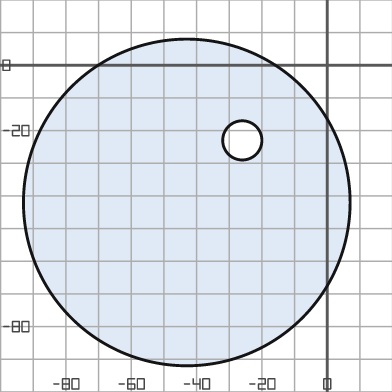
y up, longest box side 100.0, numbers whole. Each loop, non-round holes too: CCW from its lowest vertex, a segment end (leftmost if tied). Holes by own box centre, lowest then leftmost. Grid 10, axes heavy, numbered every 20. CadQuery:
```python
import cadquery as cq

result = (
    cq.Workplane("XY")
    .moveTo(-43.0, -42.0)
    .circle(50.0)
    .moveTo(-26.0, -23.0)
    .circle(6.0)
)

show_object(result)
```